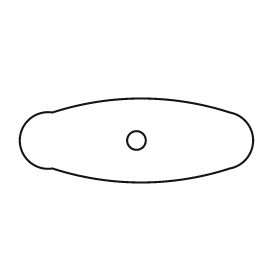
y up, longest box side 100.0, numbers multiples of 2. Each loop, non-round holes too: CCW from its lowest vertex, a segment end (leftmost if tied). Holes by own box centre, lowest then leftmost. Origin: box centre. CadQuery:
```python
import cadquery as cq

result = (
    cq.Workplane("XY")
    .moveTo(-36.0, -12.0)
    .threePointArc((2.0, -18.0), (40.0, -12.0))
    .threePointArc((50.0, 0.0), (40.0, 12.0))
    .threePointArc((2.0, 18.0), (-36.0, 12.0))
    .threePointArc((-50.0, 0.0), (-36.0, -12.0))
    .close()
    .moveTo(0.0, 0.0)
    .circle(4.0)
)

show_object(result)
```